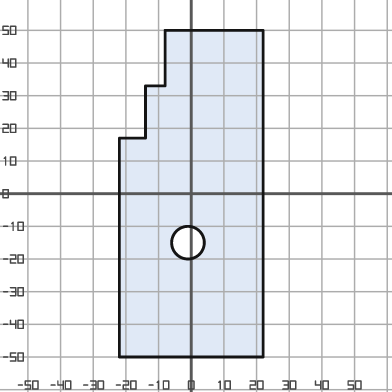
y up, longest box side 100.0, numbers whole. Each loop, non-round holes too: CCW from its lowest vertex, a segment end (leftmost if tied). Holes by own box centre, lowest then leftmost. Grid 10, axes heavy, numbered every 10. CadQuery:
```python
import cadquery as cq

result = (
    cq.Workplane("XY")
    .moveTo(-22.0, -50.0)
    .lineTo(22.0, -50.0)
    .lineTo(22.0, 50.0)
    .lineTo(-8.0, 50.0)
    .lineTo(-8.0, 33.0)
    .lineTo(-14.0, 33.0)
    .lineTo(-14.0, 17.0)
    .lineTo(-22.0, 17.0)
    .close()
    .moveTo(-1.0, -15.0)
    .circle(5.0)
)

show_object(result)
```